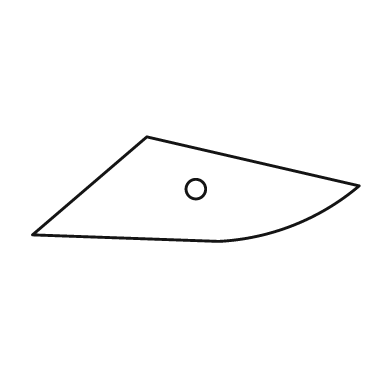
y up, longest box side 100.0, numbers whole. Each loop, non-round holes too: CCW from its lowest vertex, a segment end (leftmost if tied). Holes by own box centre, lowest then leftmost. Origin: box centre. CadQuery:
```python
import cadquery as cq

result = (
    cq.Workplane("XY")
    .moveTo(7.0, -16.0)
    .threePointArc((30.0, -11.0), (50.0, 1.0))
    .lineTo(-15.0, 16.0)
    .lineTo(-50.0, -14.0)
    .close()
    .moveTo(0.0, 0.0)
    .circle(3.0)
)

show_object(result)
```